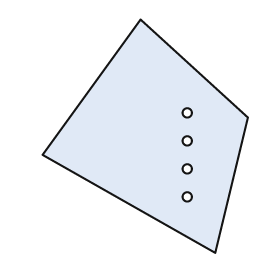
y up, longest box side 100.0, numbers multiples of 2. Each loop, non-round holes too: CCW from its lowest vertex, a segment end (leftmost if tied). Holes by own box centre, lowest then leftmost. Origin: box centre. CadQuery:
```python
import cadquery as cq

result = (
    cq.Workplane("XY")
    .moveTo(30.0, -50.0)
    .lineTo(44.0, 8.0)
    .lineTo(-2.0, 50.0)
    .lineTo(-44.0, -8.0)
    .close()
    .moveTo(18.0, -26.0)
    .circle(2.0)
    .moveTo(18.0, -14.0)
    .circle(2.0)
    .moveTo(18.0, -2.0)
    .circle(2.0)
    .moveTo(18.0, 10.0)
    .circle(2.0)
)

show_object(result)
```